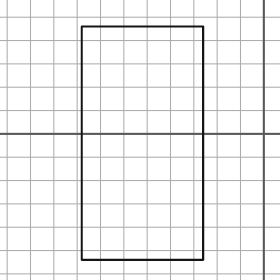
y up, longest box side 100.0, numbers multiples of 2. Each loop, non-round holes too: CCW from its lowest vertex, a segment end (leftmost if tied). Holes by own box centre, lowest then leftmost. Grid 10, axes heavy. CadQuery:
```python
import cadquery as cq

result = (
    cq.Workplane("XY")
    .moveTo(-78.0, -54.0)
    .lineTo(-26.0, -54.0)
    .lineTo(-26.0, 46.0)
    .lineTo(-78.0, 46.0)
    .close()
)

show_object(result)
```